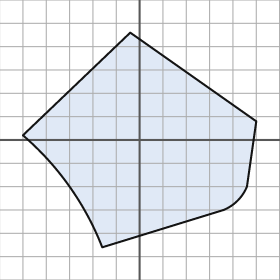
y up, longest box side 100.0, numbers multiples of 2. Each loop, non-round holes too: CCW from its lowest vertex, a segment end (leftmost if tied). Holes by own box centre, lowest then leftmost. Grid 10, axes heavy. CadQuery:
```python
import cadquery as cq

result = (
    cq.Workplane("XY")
    .moveTo(-16.0, -46.0)
    .lineTo(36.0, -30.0)
    .threePointArc((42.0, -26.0), (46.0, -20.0))
    .lineTo(50.0, 8.0)
    .lineTo(-4.0, 46.0)
    .lineTo(-50.0, 2.0)
    .threePointArc((-30.0, -20.0), (-16.0, -46.0))
    .close()
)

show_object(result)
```